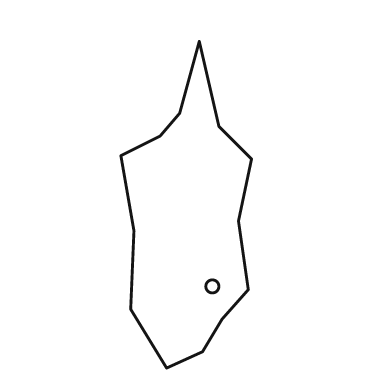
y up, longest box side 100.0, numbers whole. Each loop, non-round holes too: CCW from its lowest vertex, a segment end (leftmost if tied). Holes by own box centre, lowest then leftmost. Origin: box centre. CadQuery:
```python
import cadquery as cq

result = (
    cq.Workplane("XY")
    .moveTo(-6.0, -50.0)
    .lineTo(5.0, -45.0)
    .lineTo(11.0, -35.0)
    .lineTo(19.0, -26.0)
    .lineTo(16.0, -5.0)
    .lineTo(20.0, 14.0)
    .lineTo(10.0, 24.0)
    .lineTo(4.0, 50.0)
    .lineTo(-2.0, 28.0)
    .lineTo(-8.0, 21.0)
    .lineTo(-20.0, 15.0)
    .lineTo(-16.0, -8.0)
    .lineTo(-17.0, -32.0)
    .close()
    .moveTo(8.0, -25.0)
    .circle(2.0)
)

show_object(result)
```